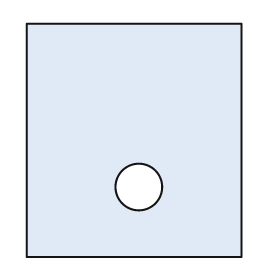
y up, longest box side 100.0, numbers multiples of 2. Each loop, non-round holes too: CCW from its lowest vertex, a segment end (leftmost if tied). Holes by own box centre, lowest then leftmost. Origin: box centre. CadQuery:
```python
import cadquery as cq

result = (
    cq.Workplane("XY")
    .moveTo(-46.0, -50.0)
    .lineTo(46.0, -50.0)
    .lineTo(46.0, 50.0)
    .lineTo(-46.0, 50.0)
    .close()
    .moveTo(2.0, -20.0)
    .circle(10.0)
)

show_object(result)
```